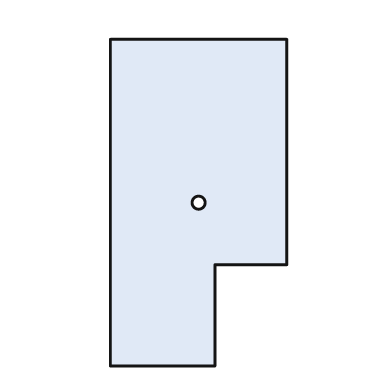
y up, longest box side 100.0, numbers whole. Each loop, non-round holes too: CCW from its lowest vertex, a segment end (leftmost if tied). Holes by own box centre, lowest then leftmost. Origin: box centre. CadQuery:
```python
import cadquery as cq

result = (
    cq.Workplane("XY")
    .moveTo(-27.0, -50.0)
    .lineTo(5.0, -50.0)
    .lineTo(5.0, -19.0)
    .lineTo(27.0, -19.0)
    .lineTo(27.0, 50.0)
    .lineTo(-27.0, 50.0)
    .close()
    .moveTo(0.0, 0.0)
    .circle(2.0)
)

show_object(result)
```